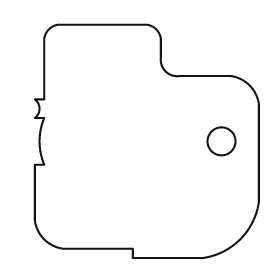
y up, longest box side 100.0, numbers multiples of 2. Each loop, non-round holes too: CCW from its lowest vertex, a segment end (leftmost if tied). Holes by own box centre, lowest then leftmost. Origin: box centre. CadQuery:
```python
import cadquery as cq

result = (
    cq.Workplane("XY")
    .moveTo(-6.0, -50.0)
    .lineTo(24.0, -50.0)
    .threePointArc((40.0, -42.0), (48.0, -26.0))
    .lineTo(48.0, 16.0)
    .threePointArc((44.0, 24.0), (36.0, 28.0))
    .lineTo(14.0, 28.0)
    .threePointArc((8.0, 30.0), (6.0, 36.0))
    .lineTo(6.0, 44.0)
    .threePointArc((4.0, 48.0), (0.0, 50.0))
    .lineTo(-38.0, 50.0)
    .threePointArc((-42.0, 48.0), (-44.0, 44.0))
    .lineTo(-44.0, 18.0)
    .lineTo(-48.0, 18.0)
    .threePointArc((-46.0, 14.0), (-48.0, 10.0))
    .lineTo(-44.0, 10.0)
    .threePointArc((-46.0, 0.0), (-44.0, -10.0))
    .lineTo(-48.0, -10.0)
    .lineTo(-48.0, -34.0)
    .threePointArc((-44.0, -42.0), (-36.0, -46.0))
    .lineTo(-6.0, -46.0)
    .close()
    .moveTo(32.0, 0.0)
    .circle(6.0)
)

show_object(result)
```